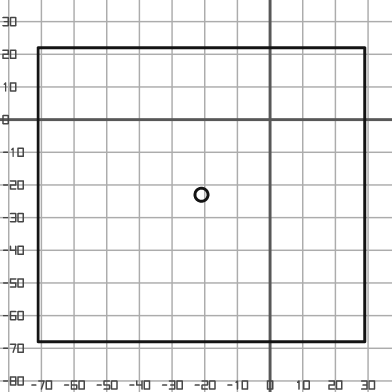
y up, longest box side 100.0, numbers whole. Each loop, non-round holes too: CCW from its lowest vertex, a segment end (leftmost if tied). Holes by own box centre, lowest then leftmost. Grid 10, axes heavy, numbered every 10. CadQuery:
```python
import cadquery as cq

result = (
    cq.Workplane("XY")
    .moveTo(-71.0, -68.0)
    .lineTo(29.0, -68.0)
    .lineTo(29.0, 22.0)
    .lineTo(-71.0, 22.0)
    .close()
    .moveTo(-21.0, -23.0)
    .circle(2.0)
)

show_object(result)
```